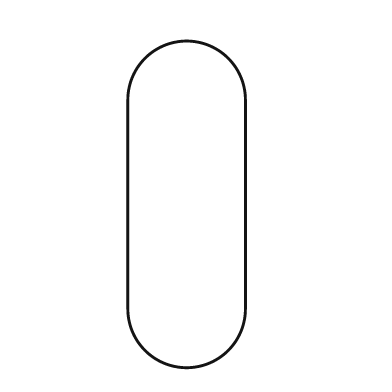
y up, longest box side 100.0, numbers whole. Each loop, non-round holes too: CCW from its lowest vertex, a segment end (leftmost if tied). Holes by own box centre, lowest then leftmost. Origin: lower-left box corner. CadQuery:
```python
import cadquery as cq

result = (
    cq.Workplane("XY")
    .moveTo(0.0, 18.0)
    .threePointArc((18.0, 0.0), (36.0, 18.0))
    .lineTo(36.0, 82.0)
    .threePointArc((18.0, 100.0), (0.0, 82.0))
    .close()
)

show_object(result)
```